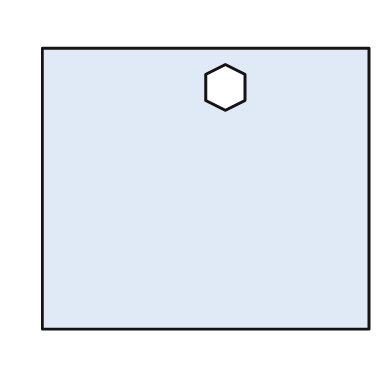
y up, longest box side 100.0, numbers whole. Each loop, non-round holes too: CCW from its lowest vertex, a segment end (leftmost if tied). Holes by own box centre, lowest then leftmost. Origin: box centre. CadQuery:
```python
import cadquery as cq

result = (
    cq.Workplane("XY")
    .moveTo(-50.0, -43.0)
    .lineTo(50.0, -43.0)
    .lineTo(50.0, 43.0)
    .lineTo(-50.0, 43.0)
    .close()
    .moveTo(6.0, 24.0)
    .lineTo(12.0, 27.0)
    .lineTo(12.0, 35.0)
    .lineTo(6.0, 38.0)
    .lineTo(0.0, 35.0)
    .lineTo(0.0, 27.0)
    .close()
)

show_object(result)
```